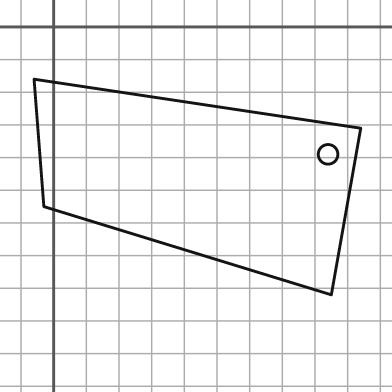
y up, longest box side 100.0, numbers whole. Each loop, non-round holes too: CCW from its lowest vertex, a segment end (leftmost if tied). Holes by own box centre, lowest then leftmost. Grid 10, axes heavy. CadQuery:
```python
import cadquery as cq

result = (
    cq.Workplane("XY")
    .moveTo(85.0, -82.0)
    .lineTo(94.0, -31.0)
    .lineTo(-6.0, -16.0)
    .lineTo(-3.0, -55.0)
    .close()
    .moveTo(84.0, -39.0)
    .circle(3.0)
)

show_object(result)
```